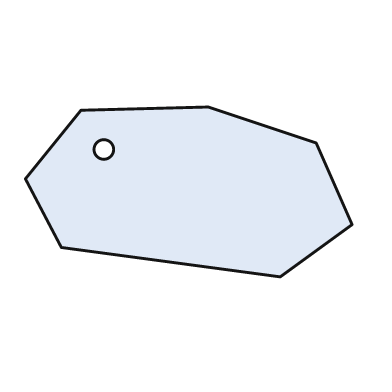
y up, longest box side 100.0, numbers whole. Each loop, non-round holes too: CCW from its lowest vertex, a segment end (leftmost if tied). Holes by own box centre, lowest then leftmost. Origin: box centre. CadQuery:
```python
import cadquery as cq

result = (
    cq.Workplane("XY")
    .moveTo(28.0, -26.0)
    .lineTo(50.0, -10.0)
    .lineTo(39.0, 15.0)
    .lineTo(6.0, 26.0)
    .lineTo(-33.0, 25.0)
    .lineTo(-50.0, 4.0)
    .lineTo(-39.0, -17.0)
    .close()
    .moveTo(-26.0, 13.0)
    .circle(3.0)
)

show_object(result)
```